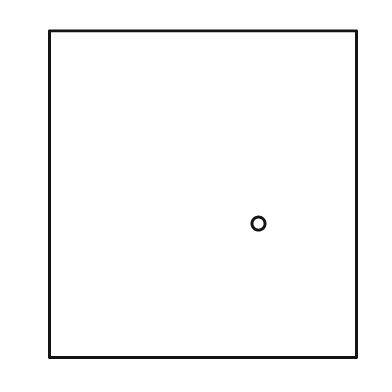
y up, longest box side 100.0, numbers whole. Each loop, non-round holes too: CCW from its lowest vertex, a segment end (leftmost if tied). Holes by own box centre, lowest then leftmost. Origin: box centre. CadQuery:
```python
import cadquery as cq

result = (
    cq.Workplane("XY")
    .moveTo(-47.0, -50.0)
    .lineTo(47.0, -50.0)
    .lineTo(47.0, 50.0)
    .lineTo(-47.0, 50.0)
    .close()
    .moveTo(17.0, -9.0)
    .circle(2.0)
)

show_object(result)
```